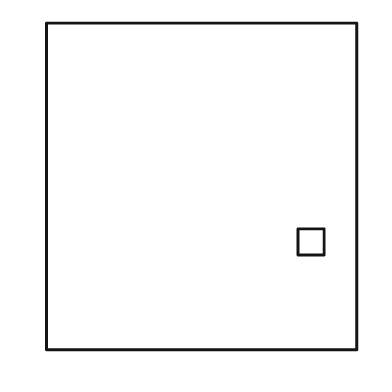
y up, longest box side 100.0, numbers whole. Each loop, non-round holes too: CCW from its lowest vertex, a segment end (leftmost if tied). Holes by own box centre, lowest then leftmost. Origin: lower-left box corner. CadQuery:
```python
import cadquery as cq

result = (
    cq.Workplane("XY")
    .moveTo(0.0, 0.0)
    .lineTo(95.0, 0.0)
    .lineTo(95.0, 100.0)
    .lineTo(0.0, 100.0)
    .close()
    .moveTo(77.0, 29.0)
    .lineTo(85.0, 29.0)
    .lineTo(85.0, 37.0)
    .lineTo(77.0, 37.0)
    .close()
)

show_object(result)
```